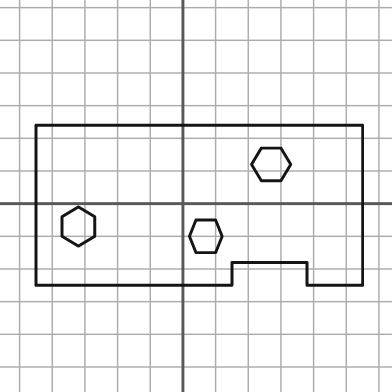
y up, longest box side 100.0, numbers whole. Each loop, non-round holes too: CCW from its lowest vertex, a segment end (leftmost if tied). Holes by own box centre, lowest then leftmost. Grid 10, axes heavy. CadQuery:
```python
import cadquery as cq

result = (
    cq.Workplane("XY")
    .moveTo(-45.0, -25.0)
    .lineTo(15.0, -25.0)
    .lineTo(15.0, -18.0)
    .lineTo(38.0, -18.0)
    .lineTo(38.0, -25.0)
    .lineTo(55.0, -25.0)
    .lineTo(55.0, 24.0)
    .lineTo(-45.0, 24.0)
    .close()
    .moveTo(4.0, -15.0)
    .lineTo(10.0, -15.0)
    .lineTo(12.0, -10.0)
    .lineTo(10.0, -5.0)
    .lineTo(4.0, -5.0)
    .lineTo(2.0, -10.0)
    .close()
    .moveTo(-32.0, -13.0)
    .lineTo(-27.0, -10.0)
    .lineTo(-27.0, -4.0)
    .lineTo(-32.0, -1.0)
    .lineTo(-37.0, -4.0)
    .lineTo(-37.0, -10.0)
    .close()
    .moveTo(24.0, 7.0)
    .lineTo(30.0, 7.0)
    .lineTo(33.0, 12.0)
    .lineTo(30.0, 17.0)
    .lineTo(24.0, 17.0)
    .lineTo(21.0, 12.0)
    .close()
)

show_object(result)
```